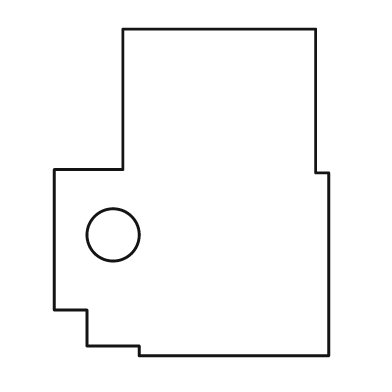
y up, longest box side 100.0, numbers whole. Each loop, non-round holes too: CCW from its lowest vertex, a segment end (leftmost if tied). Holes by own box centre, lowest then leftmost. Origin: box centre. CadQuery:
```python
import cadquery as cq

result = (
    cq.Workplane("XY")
    .moveTo(-16.0, -50.0)
    .lineTo(42.0, -50.0)
    .lineTo(42.0, 6.0)
    .lineTo(38.0, 6.0)
    .lineTo(38.0, 50.0)
    .lineTo(-21.0, 50.0)
    .lineTo(-21.0, 7.0)
    .lineTo(-42.0, 7.0)
    .lineTo(-42.0, -36.0)
    .lineTo(-32.0, -36.0)
    .lineTo(-32.0, -47.0)
    .lineTo(-16.0, -47.0)
    .close()
    .moveTo(-24.0, -13.0)
    .circle(8.0)
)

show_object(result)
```